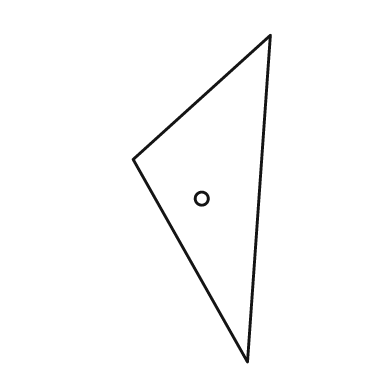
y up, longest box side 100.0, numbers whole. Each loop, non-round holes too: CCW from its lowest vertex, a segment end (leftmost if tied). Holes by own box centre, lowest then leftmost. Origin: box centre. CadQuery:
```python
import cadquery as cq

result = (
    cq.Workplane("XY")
    .moveTo(14.0, -50.0)
    .lineTo(21.0, 50.0)
    .lineTo(-21.0, 12.0)
    .close()
    .moveTo(0.0, 0.0)
    .circle(2.0)
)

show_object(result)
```